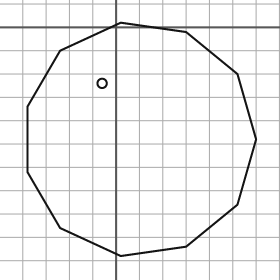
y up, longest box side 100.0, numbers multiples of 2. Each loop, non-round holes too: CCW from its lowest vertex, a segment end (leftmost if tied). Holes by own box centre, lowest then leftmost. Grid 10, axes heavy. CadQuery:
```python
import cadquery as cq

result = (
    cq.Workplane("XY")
    .moveTo(2.0, -98.0)
    .lineTo(30.0, -94.0)
    .lineTo(52.0, -76.0)
    .lineTo(60.0, -48.0)
    .lineTo(52.0, -20.0)
    .lineTo(30.0, -2.0)
    .lineTo(2.0, 2.0)
    .lineTo(-24.0, -10.0)
    .lineTo(-38.0, -34.0)
    .lineTo(-38.0, -62.0)
    .lineTo(-24.0, -86.0)
    .close()
    .moveTo(-6.0, -24.0)
    .circle(2.0)
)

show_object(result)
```